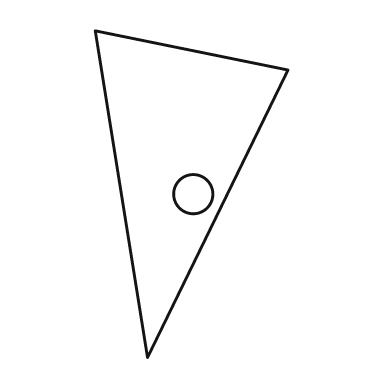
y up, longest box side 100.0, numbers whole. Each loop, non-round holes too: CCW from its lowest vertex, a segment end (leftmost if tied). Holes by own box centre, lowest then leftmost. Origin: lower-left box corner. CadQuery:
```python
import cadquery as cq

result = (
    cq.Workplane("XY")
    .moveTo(16.0, 0.0)
    .lineTo(59.0, 88.0)
    .lineTo(0.0, 100.0)
    .close()
    .moveTo(30.0, 50.0)
    .circle(6.0)
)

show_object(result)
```